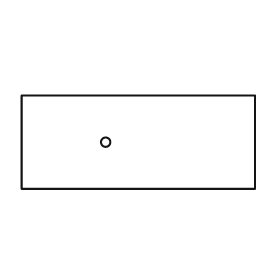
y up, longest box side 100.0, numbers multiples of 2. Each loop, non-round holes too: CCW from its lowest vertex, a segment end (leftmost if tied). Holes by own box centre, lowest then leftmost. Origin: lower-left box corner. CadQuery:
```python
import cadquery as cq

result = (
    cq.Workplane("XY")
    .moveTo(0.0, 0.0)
    .lineTo(100.0, 0.0)
    .lineTo(100.0, 40.0)
    .lineTo(0.0, 40.0)
    .close()
    .moveTo(36.0, 20.0)
    .circle(2.0)
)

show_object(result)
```